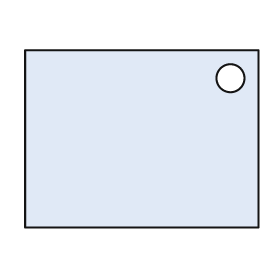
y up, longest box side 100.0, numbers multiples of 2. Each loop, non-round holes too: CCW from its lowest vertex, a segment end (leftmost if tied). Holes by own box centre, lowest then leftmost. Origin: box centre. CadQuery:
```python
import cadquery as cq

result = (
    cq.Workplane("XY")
    .moveTo(-50.0, -38.0)
    .lineTo(50.0, -38.0)
    .lineTo(50.0, 38.0)
    .lineTo(-50.0, 38.0)
    .close()
    .moveTo(38.0, 26.0)
    .circle(6.0)
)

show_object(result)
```